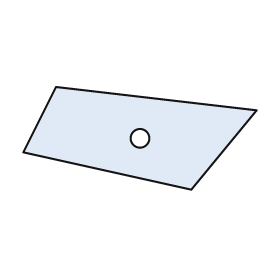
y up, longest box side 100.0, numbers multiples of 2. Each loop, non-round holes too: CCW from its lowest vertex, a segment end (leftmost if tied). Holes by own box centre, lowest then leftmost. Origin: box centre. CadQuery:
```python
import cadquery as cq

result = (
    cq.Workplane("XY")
    .moveTo(22.0, -22.0)
    .lineTo(50.0, 12.0)
    .lineTo(-36.0, 22.0)
    .lineTo(-50.0, -6.0)
    .close()
    .moveTo(0.0, 0.0)
    .circle(4.0)
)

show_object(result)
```